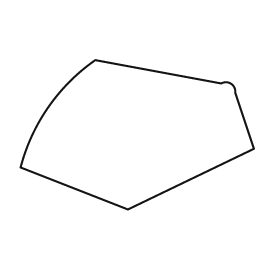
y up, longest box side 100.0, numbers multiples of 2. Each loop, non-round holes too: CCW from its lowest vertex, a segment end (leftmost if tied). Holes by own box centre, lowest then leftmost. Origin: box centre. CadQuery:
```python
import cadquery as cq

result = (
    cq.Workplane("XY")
    .moveTo(-4.0, -32.0)
    .lineTo(50.0, -6.0)
    .lineTo(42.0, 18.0)
    .threePointArc((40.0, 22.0), (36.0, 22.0))
    .lineTo(-18.0, 32.0)
    .threePointArc((-38.0, 12.0), (-50.0, -14.0))
    .close()
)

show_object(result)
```